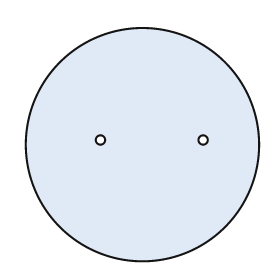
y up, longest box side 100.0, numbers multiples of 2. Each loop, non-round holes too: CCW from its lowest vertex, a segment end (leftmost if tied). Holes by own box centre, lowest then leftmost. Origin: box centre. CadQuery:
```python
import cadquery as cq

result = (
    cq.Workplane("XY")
    .moveTo(0.0, 0.0)
    .circle(50.0)
    .moveTo(-18.0, 2.0)
    .circle(2.0)
    .moveTo(26.0, 2.0)
    .circle(2.0)
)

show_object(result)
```